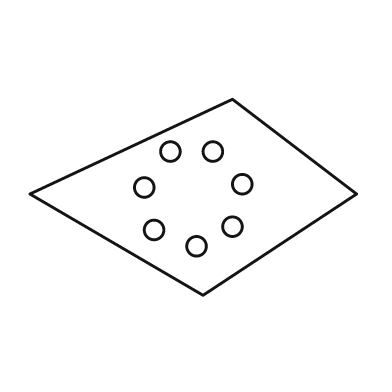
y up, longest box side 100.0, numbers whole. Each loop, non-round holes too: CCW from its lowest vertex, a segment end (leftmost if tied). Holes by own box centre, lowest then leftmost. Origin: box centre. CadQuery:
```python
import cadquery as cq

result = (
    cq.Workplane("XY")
    .moveTo(3.0, -30.0)
    .lineTo(50.0, 1.0)
    .lineTo(12.0, 30.0)
    .lineTo(-50.0, 1.0)
    .close()
    .moveTo(1.0, -15.0)
    .circle(3.0)
    .moveTo(-12.0, -10.0)
    .circle(3.0)
    .moveTo(12.0, -9.0)
    .circle(3.0)
    .moveTo(-15.0, 3.0)
    .circle(3.0)
    .moveTo(15.0, 4.0)
    .circle(3.0)
    .moveTo(-7.0, 14.0)
    .circle(3.0)
    .moveTo(6.0, 14.0)
    .circle(3.0)
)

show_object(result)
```